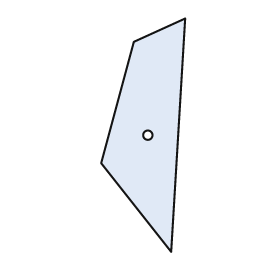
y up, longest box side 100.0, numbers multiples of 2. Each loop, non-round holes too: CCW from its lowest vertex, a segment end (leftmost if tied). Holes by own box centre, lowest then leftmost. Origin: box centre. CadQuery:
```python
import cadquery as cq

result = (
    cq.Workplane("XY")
    .moveTo(12.0, -50.0)
    .lineTo(18.0, 50.0)
    .lineTo(-4.0, 40.0)
    .lineTo(-18.0, -12.0)
    .close()
    .moveTo(2.0, 0.0)
    .circle(2.0)
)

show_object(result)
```